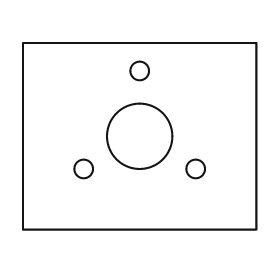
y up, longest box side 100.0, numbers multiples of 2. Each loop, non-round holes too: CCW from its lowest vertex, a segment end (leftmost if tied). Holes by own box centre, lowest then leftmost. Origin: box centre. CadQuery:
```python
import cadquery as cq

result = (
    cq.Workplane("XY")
    .moveTo(-50.0, -40.0)
    .lineTo(50.0, -40.0)
    .lineTo(50.0, 40.0)
    .lineTo(-50.0, 40.0)
    .close()
    .moveTo(-24.0, -14.0)
    .circle(4.0)
    .moveTo(24.0, -14.0)
    .circle(4.0)
    .moveTo(0.0, 0.0)
    .circle(14.0)
    .moveTo(0.0, 28.0)
    .circle(4.0)
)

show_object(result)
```